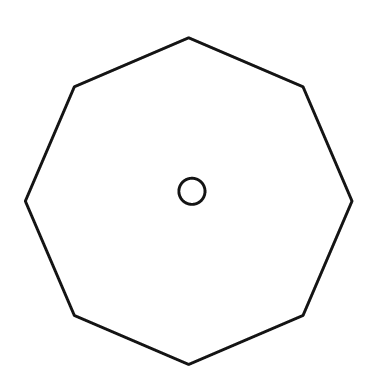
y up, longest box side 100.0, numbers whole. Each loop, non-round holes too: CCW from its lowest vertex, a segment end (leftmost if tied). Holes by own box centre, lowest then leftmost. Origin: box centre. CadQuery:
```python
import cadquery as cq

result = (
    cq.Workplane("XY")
    .moveTo(0.0, -50.0)
    .lineTo(35.0, -35.0)
    .lineTo(50.0, 0.0)
    .lineTo(35.0, 35.0)
    .lineTo(0.0, 50.0)
    .lineTo(-35.0, 35.0)
    .lineTo(-50.0, 0.0)
    .lineTo(-35.0, -35.0)
    .close()
    .moveTo(1.0, 3.0)
    .circle(4.0)
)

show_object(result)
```